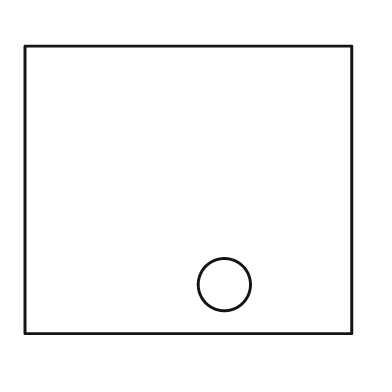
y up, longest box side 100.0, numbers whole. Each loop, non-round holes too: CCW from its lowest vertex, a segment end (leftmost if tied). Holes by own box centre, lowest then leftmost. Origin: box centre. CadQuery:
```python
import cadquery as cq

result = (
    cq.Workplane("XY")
    .moveTo(-50.0, -44.0)
    .lineTo(50.0, -44.0)
    .lineTo(50.0, 44.0)
    .lineTo(-50.0, 44.0)
    .close()
    .moveTo(11.0, -29.0)
    .circle(8.0)
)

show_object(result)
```